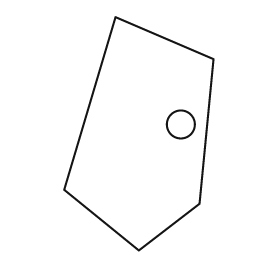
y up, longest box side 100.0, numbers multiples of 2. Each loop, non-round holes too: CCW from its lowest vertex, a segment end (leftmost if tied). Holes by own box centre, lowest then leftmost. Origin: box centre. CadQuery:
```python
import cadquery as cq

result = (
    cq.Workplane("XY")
    .moveTo(0.0, -50.0)
    .lineTo(26.0, -30.0)
    .lineTo(32.0, 32.0)
    .lineTo(-10.0, 50.0)
    .lineTo(-32.0, -24.0)
    .close()
    .moveTo(18.0, 4.0)
    .circle(6.0)
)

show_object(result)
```